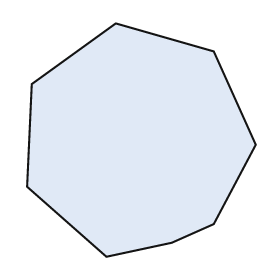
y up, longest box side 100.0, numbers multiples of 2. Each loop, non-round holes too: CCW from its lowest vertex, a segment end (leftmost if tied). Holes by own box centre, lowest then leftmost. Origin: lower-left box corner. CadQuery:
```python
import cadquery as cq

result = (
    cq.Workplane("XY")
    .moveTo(34.0, 0.0)
    .lineTo(62.0, 6.0)
    .lineTo(80.0, 14.0)
    .lineTo(98.0, 48.0)
    .lineTo(80.0, 88.0)
    .lineTo(38.0, 100.0)
    .lineTo(2.0, 74.0)
    .lineTo(0.0, 30.0)
    .close()
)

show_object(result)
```